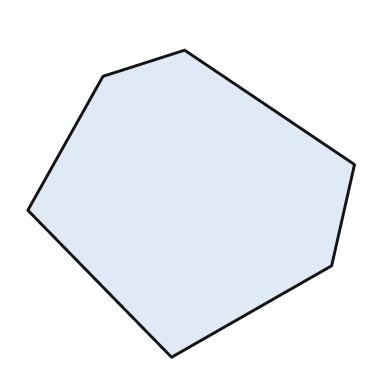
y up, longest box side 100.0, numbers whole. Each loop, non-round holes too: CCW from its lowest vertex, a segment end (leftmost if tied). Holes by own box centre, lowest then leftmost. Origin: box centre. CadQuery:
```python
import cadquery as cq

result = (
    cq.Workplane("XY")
    .moveTo(-6.0, -47.0)
    .lineTo(43.0, -19.0)
    .lineTo(50.0, 12.0)
    .lineTo(-2.0, 47.0)
    .lineTo(-27.0, 39.0)
    .lineTo(-50.0, -2.0)
    .close()
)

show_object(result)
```